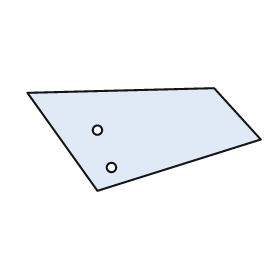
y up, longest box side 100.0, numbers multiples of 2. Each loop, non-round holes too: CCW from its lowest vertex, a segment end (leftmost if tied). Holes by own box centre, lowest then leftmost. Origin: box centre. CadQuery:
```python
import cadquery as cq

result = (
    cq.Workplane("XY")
    .moveTo(-20.0, -22.0)
    .lineTo(50.0, 0.0)
    .lineTo(30.0, 22.0)
    .lineTo(-50.0, 20.0)
    .close()
    .moveTo(-14.0, -12.0)
    .circle(2.0)
    .moveTo(-20.0, 4.0)
    .circle(2.0)
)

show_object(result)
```